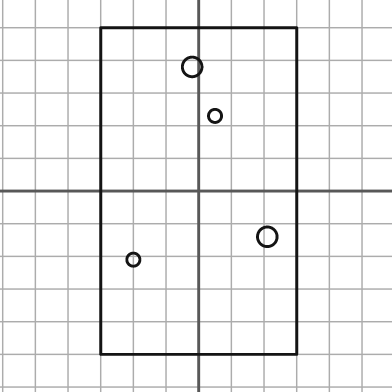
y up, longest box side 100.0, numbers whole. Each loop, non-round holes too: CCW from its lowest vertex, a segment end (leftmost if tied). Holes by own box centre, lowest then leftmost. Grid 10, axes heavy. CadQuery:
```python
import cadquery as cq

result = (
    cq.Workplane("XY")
    .moveTo(-30.0, -50.0)
    .lineTo(30.0, -50.0)
    .lineTo(30.0, 50.0)
    .lineTo(-30.0, 50.0)
    .close()
    .moveTo(-20.0, -21.0)
    .circle(2.0)
    .moveTo(21.0, -14.0)
    .circle(3.0)
    .moveTo(5.0, 23.0)
    .circle(2.0)
    .moveTo(-2.0, 38.0)
    .circle(3.0)
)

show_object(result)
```